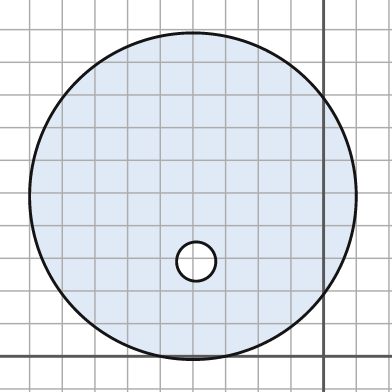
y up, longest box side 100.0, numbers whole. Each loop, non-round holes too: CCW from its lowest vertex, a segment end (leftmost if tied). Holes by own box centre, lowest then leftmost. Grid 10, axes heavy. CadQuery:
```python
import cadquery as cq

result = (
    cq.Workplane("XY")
    .moveTo(-40.0, 49.0)
    .circle(50.0)
    .moveTo(-39.0, 29.0)
    .circle(6.0)
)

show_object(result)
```